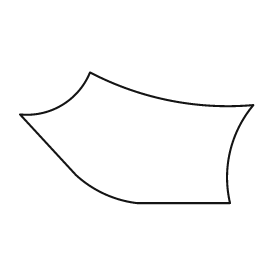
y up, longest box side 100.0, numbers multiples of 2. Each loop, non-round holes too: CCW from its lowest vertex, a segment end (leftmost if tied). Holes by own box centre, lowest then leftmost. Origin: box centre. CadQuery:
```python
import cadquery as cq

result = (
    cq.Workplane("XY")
    .moveTo(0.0, -28.0)
    .lineTo(40.0, -28.0)
    .threePointArc((40.0, -6.0), (50.0, 14.0))
    .threePointArc((14.0, 16.0), (-20.0, 28.0))
    .threePointArc((-32.0, 14.0), (-50.0, 10.0))
    .lineTo(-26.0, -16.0)
    .threePointArc((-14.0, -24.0), (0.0, -28.0))
    .close()
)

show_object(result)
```